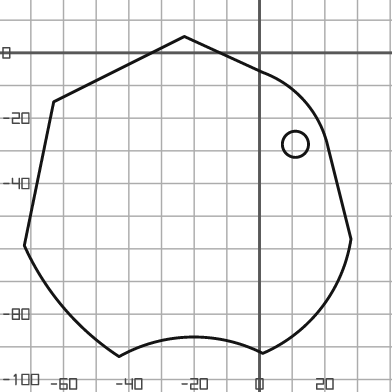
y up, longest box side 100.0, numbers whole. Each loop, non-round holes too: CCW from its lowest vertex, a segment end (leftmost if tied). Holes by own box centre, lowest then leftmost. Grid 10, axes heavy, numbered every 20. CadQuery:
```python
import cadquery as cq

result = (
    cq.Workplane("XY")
    .moveTo(-43.0, -93.0)
    .threePointArc((-21.0, -87.0), (1.0, -92.0))
    .threePointArc((19.0, -78.0), (28.0, -57.0))
    .lineTo(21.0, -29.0)
    .threePointArc((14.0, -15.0), (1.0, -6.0))
    .lineTo(-23.0, 5.0)
    .lineTo(-63.0, -15.0)
    .lineTo(-72.0, -59.0)
    .threePointArc((-60.0, -78.0), (-43.0, -93.0))
    .close()
    .moveTo(11.0, -28.0)
    .circle(4.0)
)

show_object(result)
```